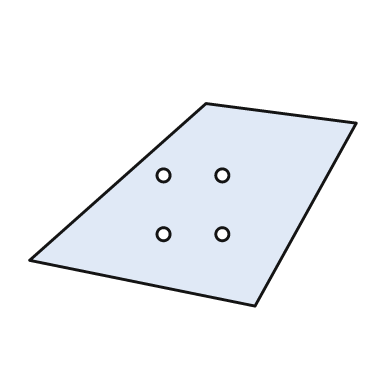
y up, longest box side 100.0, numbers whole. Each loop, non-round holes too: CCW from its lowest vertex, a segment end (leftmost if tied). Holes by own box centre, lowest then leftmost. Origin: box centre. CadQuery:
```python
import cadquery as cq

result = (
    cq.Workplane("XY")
    .moveTo(19.0, -31.0)
    .lineTo(50.0, 25.0)
    .lineTo(4.0, 31.0)
    .lineTo(-50.0, -17.0)
    .close()
    .moveTo(-9.0, -9.0)
    .circle(2.0)
    .moveTo(9.0, -9.0)
    .circle(2.0)
    .moveTo(-9.0, 9.0)
    .circle(2.0)
    .moveTo(9.0, 9.0)
    .circle(2.0)
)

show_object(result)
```